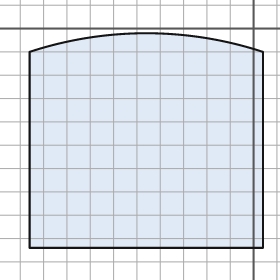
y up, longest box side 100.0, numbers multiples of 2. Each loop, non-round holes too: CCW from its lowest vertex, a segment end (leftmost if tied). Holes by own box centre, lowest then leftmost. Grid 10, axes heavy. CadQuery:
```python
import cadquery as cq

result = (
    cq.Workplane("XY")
    .moveTo(-96.0, -94.0)
    .lineTo(4.0, -94.0)
    .lineTo(4.0, -10.0)
    .threePointArc((-46.0, -2.0), (-96.0, -10.0))
    .close()
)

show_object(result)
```